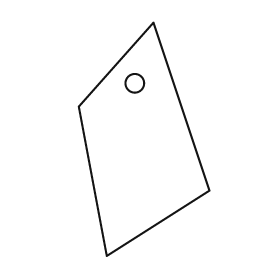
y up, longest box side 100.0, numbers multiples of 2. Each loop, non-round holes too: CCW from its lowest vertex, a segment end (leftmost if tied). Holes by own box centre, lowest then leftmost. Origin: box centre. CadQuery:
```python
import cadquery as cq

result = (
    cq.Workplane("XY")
    .moveTo(-16.0, -50.0)
    .lineTo(28.0, -22.0)
    .lineTo(4.0, 50.0)
    .lineTo(-28.0, 14.0)
    .close()
    .moveTo(-4.0, 24.0)
    .circle(4.0)
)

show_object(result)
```